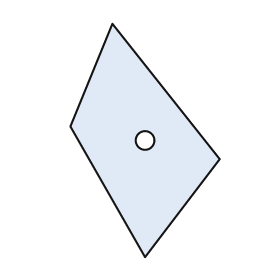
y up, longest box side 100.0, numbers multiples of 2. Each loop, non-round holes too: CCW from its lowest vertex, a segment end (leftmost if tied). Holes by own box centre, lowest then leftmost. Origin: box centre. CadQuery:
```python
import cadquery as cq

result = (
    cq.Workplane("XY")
    .moveTo(0.0, -50.0)
    .lineTo(32.0, -8.0)
    .lineTo(-14.0, 50.0)
    .lineTo(-32.0, 6.0)
    .close()
    .moveTo(0.0, 0.0)
    .circle(4.0)
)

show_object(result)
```